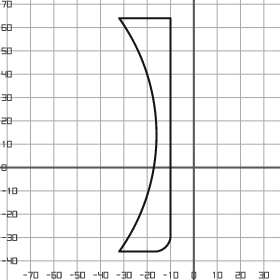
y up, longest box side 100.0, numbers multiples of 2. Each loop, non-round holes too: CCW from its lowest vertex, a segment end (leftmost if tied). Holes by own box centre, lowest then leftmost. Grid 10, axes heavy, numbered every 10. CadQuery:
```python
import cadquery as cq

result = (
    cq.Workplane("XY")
    .moveTo(-32.0, -36.0)
    .lineTo(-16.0, -36.0)
    .threePointArc((-12.0, -34.0), (-10.0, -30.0))
    .lineTo(-10.0, 64.0)
    .lineTo(-32.0, 64.0)
    .threePointArc((-16.0, 14.0), (-32.0, -36.0))
    .close()
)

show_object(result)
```